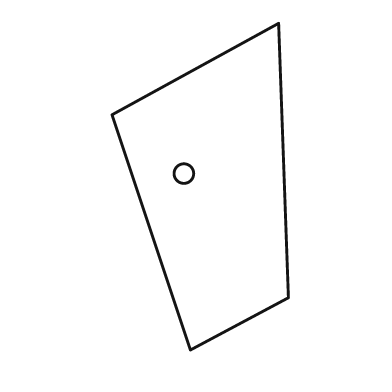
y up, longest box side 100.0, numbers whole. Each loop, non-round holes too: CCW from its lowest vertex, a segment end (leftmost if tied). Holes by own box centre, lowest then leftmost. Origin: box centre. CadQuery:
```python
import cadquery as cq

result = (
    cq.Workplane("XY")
    .moveTo(-3.0, -50.0)
    .lineTo(27.0, -34.0)
    .lineTo(24.0, 50.0)
    .lineTo(-27.0, 22.0)
    .close()
    .moveTo(-5.0, 4.0)
    .circle(3.0)
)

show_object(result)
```